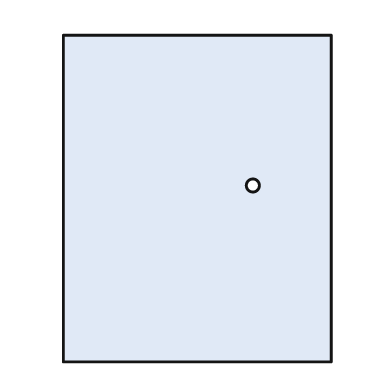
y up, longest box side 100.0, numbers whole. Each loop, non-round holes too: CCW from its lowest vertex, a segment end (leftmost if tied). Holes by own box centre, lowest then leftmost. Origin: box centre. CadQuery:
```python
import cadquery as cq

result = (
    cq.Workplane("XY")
    .moveTo(-41.0, -50.0)
    .lineTo(41.0, -50.0)
    .lineTo(41.0, 50.0)
    .lineTo(-41.0, 50.0)
    .close()
    .moveTo(17.0, 4.0)
    .circle(2.0)
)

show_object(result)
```